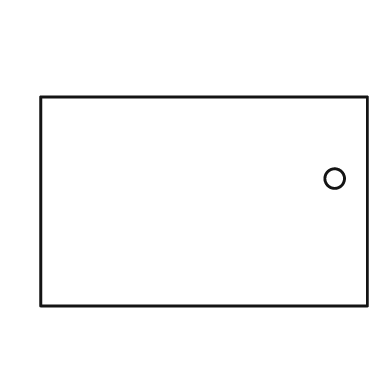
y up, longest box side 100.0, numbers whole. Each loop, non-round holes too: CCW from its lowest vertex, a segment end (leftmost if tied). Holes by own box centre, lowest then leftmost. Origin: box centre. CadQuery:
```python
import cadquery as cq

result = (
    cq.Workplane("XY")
    .moveTo(-50.0, -32.0)
    .lineTo(50.0, -32.0)
    .lineTo(50.0, 32.0)
    .lineTo(-50.0, 32.0)
    .close()
    .moveTo(40.0, 7.0)
    .circle(3.0)
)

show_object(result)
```